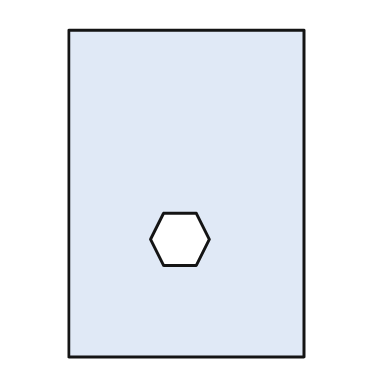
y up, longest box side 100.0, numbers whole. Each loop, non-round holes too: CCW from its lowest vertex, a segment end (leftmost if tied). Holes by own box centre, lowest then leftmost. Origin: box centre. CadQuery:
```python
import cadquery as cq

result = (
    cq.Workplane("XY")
    .moveTo(-36.0, -50.0)
    .lineTo(36.0, -50.0)
    .lineTo(36.0, 50.0)
    .lineTo(-36.0, 50.0)
    .close()
    .moveTo(-7.0, -22.0)
    .lineTo(3.0, -22.0)
    .lineTo(7.0, -14.0)
    .lineTo(3.0, -6.0)
    .lineTo(-7.0, -6.0)
    .lineTo(-11.0, -14.0)
    .close()
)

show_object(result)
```